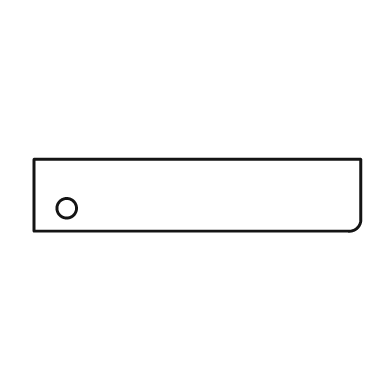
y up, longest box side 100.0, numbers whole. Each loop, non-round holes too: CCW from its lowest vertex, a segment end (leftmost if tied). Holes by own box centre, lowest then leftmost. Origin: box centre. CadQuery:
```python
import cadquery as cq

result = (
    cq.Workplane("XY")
    .moveTo(-50.0, -11.0)
    .lineTo(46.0, -11.0)
    .threePointArc((49.0, -10.0), (50.0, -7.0))
    .lineTo(50.0, 11.0)
    .lineTo(-50.0, 11.0)
    .close()
    .moveTo(-40.0, -4.0)
    .circle(3.0)
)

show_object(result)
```